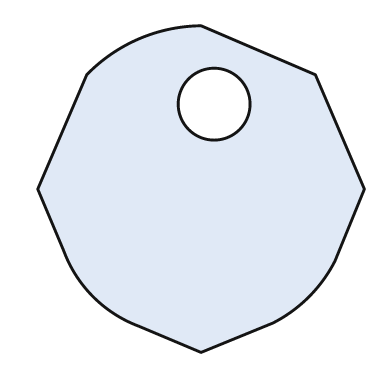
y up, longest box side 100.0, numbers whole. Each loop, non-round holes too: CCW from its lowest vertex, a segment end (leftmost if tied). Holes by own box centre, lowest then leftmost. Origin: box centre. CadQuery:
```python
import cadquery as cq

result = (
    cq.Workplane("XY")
    .moveTo(0.0, -50.0)
    .lineTo(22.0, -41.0)
    .threePointArc((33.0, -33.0), (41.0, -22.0))
    .lineTo(50.0, 0.0)
    .lineTo(35.0, 35.0)
    .lineTo(0.0, 50.0)
    .threePointArc((-19.0, 46.0), (-35.0, 35.0))
    .lineTo(-50.0, 0.0)
    .lineTo(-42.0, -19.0)
    .threePointArc((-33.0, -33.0), (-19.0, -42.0))
    .close()
    .moveTo(4.0, 26.0)
    .circle(11.0)
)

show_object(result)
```